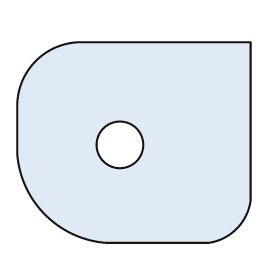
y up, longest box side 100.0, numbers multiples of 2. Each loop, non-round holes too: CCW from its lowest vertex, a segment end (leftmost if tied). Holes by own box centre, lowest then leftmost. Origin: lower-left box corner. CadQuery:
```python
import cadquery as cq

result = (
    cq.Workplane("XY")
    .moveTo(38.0, 0.0)
    .lineTo(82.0, 0.0)
    .threePointArc((94.0, 6.0), (100.0, 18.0))
    .lineTo(100.0, 86.0)
    .lineTo(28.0, 86.0)
    .threePointArc((8.0, 78.0), (0.0, 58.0))
    .lineTo(0.0, 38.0)
    .threePointArc((12.0, 12.0), (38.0, 0.0))
    .close()
    .moveTo(44.0, 42.0)
    .circle(10.0)
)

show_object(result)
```